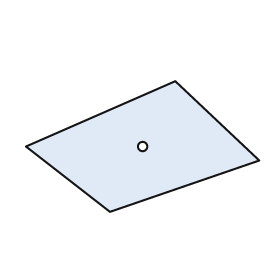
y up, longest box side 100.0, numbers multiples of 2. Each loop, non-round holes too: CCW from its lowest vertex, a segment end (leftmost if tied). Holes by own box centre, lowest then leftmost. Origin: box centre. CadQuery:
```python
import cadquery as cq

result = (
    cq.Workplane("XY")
    .moveTo(-14.0, -28.0)
    .lineTo(50.0, -6.0)
    .lineTo(14.0, 28.0)
    .lineTo(-50.0, 0.0)
    .close()
    .moveTo(0.0, 0.0)
    .circle(2.0)
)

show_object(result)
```